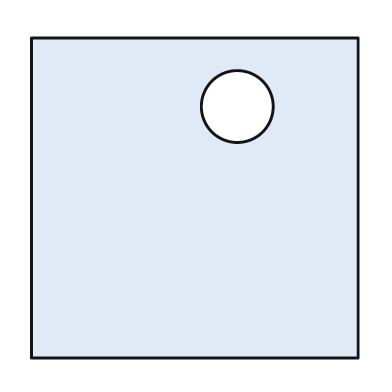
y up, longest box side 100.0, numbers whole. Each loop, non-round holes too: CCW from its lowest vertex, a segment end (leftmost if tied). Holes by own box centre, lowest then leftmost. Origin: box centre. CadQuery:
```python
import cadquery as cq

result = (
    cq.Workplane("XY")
    .moveTo(-50.0, -49.0)
    .lineTo(50.0, -49.0)
    .lineTo(50.0, 49.0)
    .lineTo(-50.0, 49.0)
    .close()
    .moveTo(13.0, 28.0)
    .circle(11.0)
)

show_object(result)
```